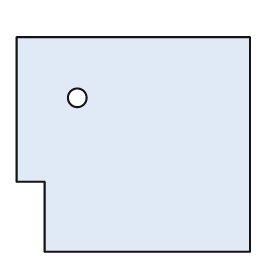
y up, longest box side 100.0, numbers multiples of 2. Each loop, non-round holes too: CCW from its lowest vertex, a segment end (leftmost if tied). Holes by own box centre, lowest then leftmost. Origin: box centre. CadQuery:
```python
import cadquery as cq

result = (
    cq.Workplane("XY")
    .moveTo(-38.0, -46.0)
    .lineTo(50.0, -46.0)
    .lineTo(50.0, 46.0)
    .lineTo(-50.0, 46.0)
    .lineTo(-50.0, -16.0)
    .lineTo(-38.0, -16.0)
    .close()
    .moveTo(-24.0, 20.0)
    .circle(4.0)
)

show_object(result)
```